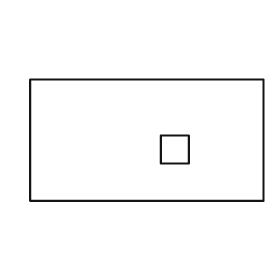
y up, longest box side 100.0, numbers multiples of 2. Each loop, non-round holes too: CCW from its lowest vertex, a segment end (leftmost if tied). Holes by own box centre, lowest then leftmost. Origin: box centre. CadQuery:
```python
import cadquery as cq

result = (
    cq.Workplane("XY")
    .moveTo(-50.0, -26.0)
    .lineTo(50.0, -26.0)
    .lineTo(50.0, 26.0)
    .lineTo(-50.0, 26.0)
    .close()
    .moveTo(6.0, -10.0)
    .lineTo(18.0, -10.0)
    .lineTo(18.0, 2.0)
    .lineTo(6.0, 2.0)
    .close()
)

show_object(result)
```